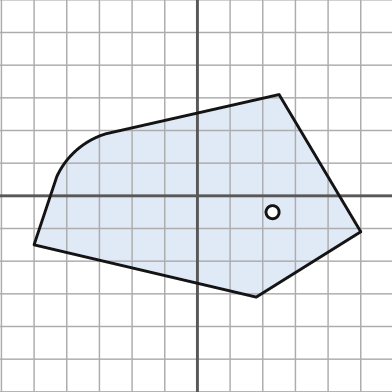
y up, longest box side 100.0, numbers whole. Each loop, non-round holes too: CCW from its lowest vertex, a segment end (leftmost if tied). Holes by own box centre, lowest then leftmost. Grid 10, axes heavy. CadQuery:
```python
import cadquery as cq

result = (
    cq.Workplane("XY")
    .moveTo(18.0, -31.0)
    .lineTo(50.0, -11.0)
    .lineTo(25.0, 31.0)
    .lineTo(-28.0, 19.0)
    .threePointArc((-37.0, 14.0), (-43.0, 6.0))
    .lineTo(-50.0, -15.0)
    .close()
    .moveTo(23.0, -5.0)
    .circle(2.0)
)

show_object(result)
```